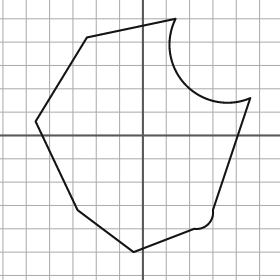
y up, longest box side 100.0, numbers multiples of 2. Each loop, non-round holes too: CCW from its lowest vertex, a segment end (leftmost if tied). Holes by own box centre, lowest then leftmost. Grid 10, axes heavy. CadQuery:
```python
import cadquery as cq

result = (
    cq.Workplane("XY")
    .moveTo(-4.0, -50.0)
    .lineTo(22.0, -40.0)
    .threePointArc((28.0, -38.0), (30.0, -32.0))
    .lineTo(46.0, 16.0)
    .threePointArc((18.0, 22.0), (14.0, 50.0))
    .lineTo(-24.0, 42.0)
    .lineTo(-46.0, 6.0)
    .lineTo(-28.0, -32.0)
    .close()
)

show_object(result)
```